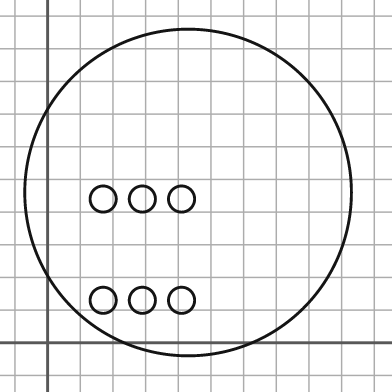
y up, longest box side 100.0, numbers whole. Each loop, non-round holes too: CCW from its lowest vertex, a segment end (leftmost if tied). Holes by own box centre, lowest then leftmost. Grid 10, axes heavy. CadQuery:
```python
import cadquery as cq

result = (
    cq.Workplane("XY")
    .moveTo(43.0, 46.0)
    .circle(50.0)
    .moveTo(17.0, 13.0)
    .circle(4.0)
    .moveTo(29.0, 13.0)
    .circle(4.0)
    .moveTo(41.0, 13.0)
    .circle(4.0)
    .moveTo(17.0, 44.0)
    .circle(4.0)
    .moveTo(29.0, 44.0)
    .circle(4.0)
    .moveTo(41.0, 44.0)
    .circle(4.0)
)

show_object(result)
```